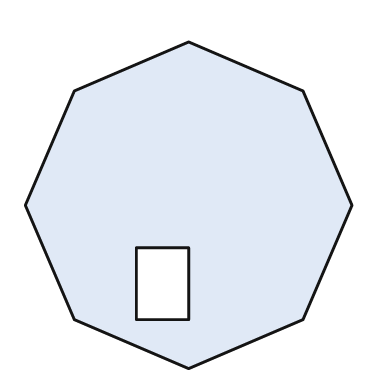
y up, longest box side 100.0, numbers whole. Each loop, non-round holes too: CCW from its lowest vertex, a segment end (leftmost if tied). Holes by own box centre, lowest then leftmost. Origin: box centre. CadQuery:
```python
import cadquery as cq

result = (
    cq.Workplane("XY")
    .moveTo(0.0, -50.0)
    .lineTo(35.0, -35.0)
    .lineTo(50.0, 0.0)
    .lineTo(35.0, 35.0)
    .lineTo(0.0, 50.0)
    .lineTo(-35.0, 35.0)
    .lineTo(-50.0, 0.0)
    .lineTo(-35.0, -35.0)
    .close()
    .moveTo(-16.0, -35.0)
    .lineTo(0.0, -35.0)
    .lineTo(0.0, -13.0)
    .lineTo(-16.0, -13.0)
    .close()
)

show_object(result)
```